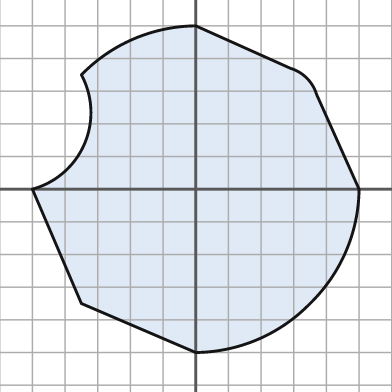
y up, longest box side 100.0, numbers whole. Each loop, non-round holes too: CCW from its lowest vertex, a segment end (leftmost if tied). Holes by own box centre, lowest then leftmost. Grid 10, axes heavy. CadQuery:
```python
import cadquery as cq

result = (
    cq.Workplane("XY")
    .moveTo(0.0, -50.0)
    .threePointArc((19.0, -46.0), (35.0, -35.0))
    .threePointArc((46.0, -19.0), (50.0, 0.0))
    .lineTo(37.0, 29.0)
    .threePointArc((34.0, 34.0), (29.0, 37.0))
    .lineTo(0.0, 50.0)
    .threePointArc((-19.0, 46.0), (-35.0, 35.0))
    .threePointArc((-34.0, 14.0), (-50.0, 0.0))
    .lineTo(-35.0, -35.0)
    .close()
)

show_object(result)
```